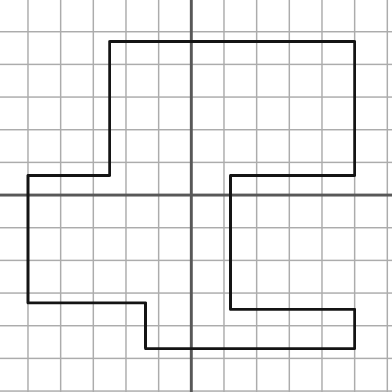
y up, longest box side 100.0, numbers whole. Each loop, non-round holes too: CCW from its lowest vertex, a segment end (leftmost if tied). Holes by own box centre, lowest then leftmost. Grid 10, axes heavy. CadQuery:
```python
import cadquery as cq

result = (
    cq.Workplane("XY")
    .moveTo(-14.0, -47.0)
    .lineTo(50.0, -47.0)
    .lineTo(50.0, -35.0)
    .lineTo(12.0, -35.0)
    .lineTo(12.0, 6.0)
    .lineTo(50.0, 6.0)
    .lineTo(50.0, 47.0)
    .lineTo(-25.0, 47.0)
    .lineTo(-25.0, 6.0)
    .lineTo(-50.0, 6.0)
    .lineTo(-50.0, -33.0)
    .lineTo(-14.0, -33.0)
    .close()
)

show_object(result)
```